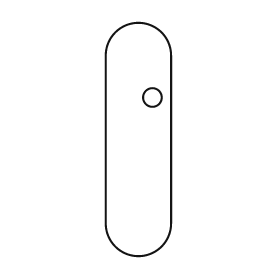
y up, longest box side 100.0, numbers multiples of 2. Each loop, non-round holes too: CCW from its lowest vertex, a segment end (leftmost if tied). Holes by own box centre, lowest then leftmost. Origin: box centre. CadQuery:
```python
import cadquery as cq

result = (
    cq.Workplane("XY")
    .moveTo(-14.0, -36.0)
    .threePointArc((0.0, -50.0), (14.0, -36.0))
    .lineTo(14.0, 36.0)
    .threePointArc((0.0, 50.0), (-14.0, 36.0))
    .close()
    .moveTo(6.0, 18.0)
    .circle(4.0)
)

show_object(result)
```